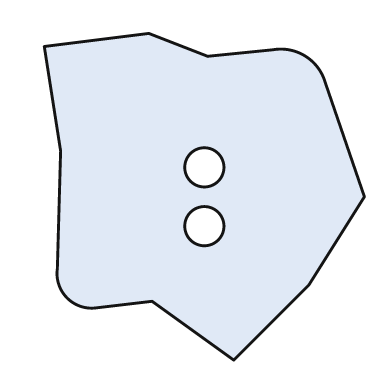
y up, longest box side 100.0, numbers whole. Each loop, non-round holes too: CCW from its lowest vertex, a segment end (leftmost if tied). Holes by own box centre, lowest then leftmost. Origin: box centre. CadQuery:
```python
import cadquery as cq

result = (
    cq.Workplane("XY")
    .moveTo(9.0, -50.0)
    .lineTo(32.0, -27.0)
    .lineTo(49.0, 0.0)
    .lineTo(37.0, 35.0)
    .threePointArc((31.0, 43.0), (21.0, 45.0))
    .lineTo(1.0, 43.0)
    .lineTo(-17.0, 50.0)
    .lineTo(-49.0, 46.0)
    .lineTo(-44.0, 14.0)
    .lineTo(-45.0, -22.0)
    .threePointArc((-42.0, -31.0), (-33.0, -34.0))
    .lineTo(-16.0, -32.0)
    .close()
    .moveTo(0.0, -9.0)
    .circle(6.0)
    .moveTo(0.0, 9.0)
    .circle(6.0)
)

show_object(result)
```